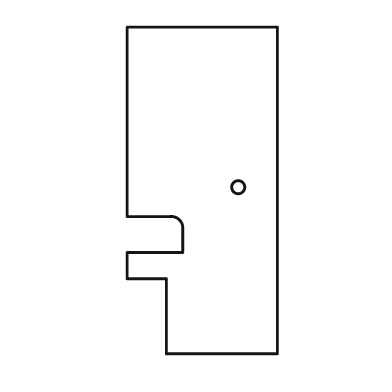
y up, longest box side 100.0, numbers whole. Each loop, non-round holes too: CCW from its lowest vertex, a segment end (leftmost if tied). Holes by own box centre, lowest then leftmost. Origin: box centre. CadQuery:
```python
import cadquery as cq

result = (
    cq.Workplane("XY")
    .moveTo(-11.0, -50.0)
    .lineTo(23.0, -50.0)
    .lineTo(23.0, 50.0)
    .lineTo(-23.0, 50.0)
    .lineTo(-23.0, -8.0)
    .lineTo(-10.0, -8.0)
    .threePointArc((-7.0, -9.0), (-6.0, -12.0))
    .lineTo(-6.0, -19.0)
    .lineTo(-23.0, -19.0)
    .lineTo(-23.0, -27.0)
    .lineTo(-11.0, -27.0)
    .close()
    .moveTo(11.0, 1.0)
    .circle(2.0)
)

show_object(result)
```